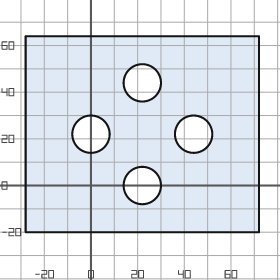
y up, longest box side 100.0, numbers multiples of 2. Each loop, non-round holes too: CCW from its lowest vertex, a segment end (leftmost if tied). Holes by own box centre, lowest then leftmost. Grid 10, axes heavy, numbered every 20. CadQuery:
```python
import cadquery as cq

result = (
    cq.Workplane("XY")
    .moveTo(-28.0, -20.0)
    .lineTo(72.0, -20.0)
    .lineTo(72.0, 64.0)
    .lineTo(-28.0, 64.0)
    .close()
    .moveTo(22.0, 0.0)
    .circle(8.0)
    .moveTo(0.0, 22.0)
    .circle(8.0)
    .moveTo(44.0, 22.0)
    .circle(8.0)
    .moveTo(22.0, 44.0)
    .circle(8.0)
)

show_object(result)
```